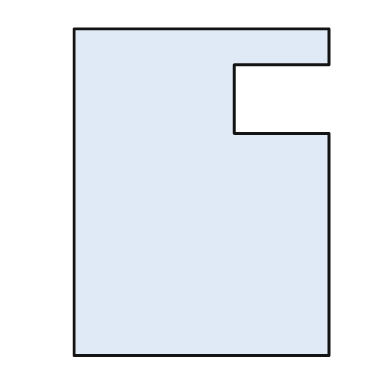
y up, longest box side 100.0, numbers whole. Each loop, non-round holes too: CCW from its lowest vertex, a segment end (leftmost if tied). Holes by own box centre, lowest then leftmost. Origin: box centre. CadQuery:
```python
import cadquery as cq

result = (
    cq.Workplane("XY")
    .moveTo(-39.0, -50.0)
    .lineTo(39.0, -50.0)
    .lineTo(39.0, 18.0)
    .lineTo(10.0, 18.0)
    .lineTo(10.0, 39.0)
    .lineTo(39.0, 39.0)
    .lineTo(39.0, 50.0)
    .lineTo(-39.0, 50.0)
    .close()
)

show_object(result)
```